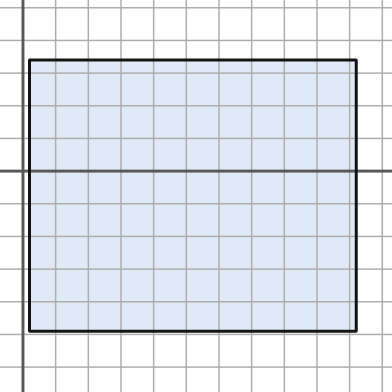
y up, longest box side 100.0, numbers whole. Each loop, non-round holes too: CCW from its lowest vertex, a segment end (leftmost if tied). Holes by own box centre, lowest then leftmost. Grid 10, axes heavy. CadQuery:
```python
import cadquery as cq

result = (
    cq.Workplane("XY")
    .moveTo(2.0, -49.0)
    .lineTo(102.0, -49.0)
    .lineTo(102.0, 34.0)
    .lineTo(2.0, 34.0)
    .close()
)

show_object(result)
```